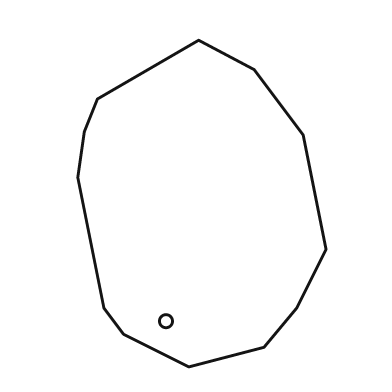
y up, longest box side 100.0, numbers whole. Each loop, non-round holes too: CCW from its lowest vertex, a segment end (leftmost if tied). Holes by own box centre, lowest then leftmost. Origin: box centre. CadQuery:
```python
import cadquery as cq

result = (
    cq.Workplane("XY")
    .moveTo(-4.0, -50.0)
    .lineTo(19.0, -44.0)
    .lineTo(29.0, -32.0)
    .lineTo(38.0, -14.0)
    .lineTo(31.0, 21.0)
    .lineTo(16.0, 41.0)
    .lineTo(-1.0, 50.0)
    .lineTo(-32.0, 32.0)
    .lineTo(-36.0, 22.0)
    .lineTo(-38.0, 8.0)
    .lineTo(-30.0, -32.0)
    .lineTo(-24.0, -40.0)
    .close()
    .moveTo(-11.0, -36.0)
    .circle(2.0)
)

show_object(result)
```